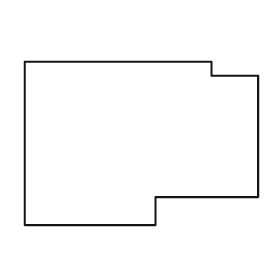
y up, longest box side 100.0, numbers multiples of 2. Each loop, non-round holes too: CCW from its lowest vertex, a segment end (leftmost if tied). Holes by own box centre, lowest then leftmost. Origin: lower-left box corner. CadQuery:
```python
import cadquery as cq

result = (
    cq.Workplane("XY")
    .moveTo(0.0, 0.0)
    .lineTo(56.0, 0.0)
    .lineTo(56.0, 12.0)
    .lineTo(100.0, 12.0)
    .lineTo(100.0, 64.0)
    .lineTo(80.0, 64.0)
    .lineTo(80.0, 70.0)
    .lineTo(0.0, 70.0)
    .close()
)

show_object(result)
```